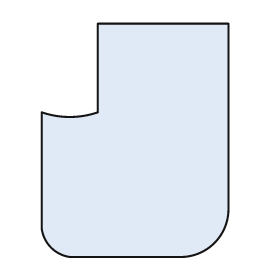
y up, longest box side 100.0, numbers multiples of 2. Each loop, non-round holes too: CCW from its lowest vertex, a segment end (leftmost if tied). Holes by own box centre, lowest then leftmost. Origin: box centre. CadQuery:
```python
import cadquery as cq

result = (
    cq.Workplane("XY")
    .moveTo(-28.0, -50.0)
    .lineTo(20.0, -50.0)
    .threePointArc((34.0, -44.0), (40.0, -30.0))
    .lineTo(40.0, 50.0)
    .lineTo(-16.0, 50.0)
    .lineTo(-16.0, 12.0)
    .threePointArc((-28.0, 10.0), (-40.0, 12.0))
    .lineTo(-40.0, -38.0)
    .threePointArc((-36.0, -46.0), (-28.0, -50.0))
    .close()
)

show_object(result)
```